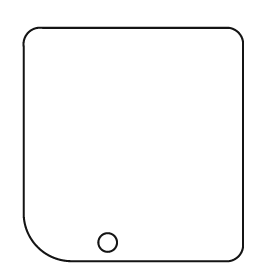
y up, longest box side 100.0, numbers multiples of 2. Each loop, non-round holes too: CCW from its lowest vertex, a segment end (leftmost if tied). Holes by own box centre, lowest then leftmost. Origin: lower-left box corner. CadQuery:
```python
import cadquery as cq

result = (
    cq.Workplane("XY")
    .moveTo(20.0, 0.0)
    .lineTo(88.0, 0.0)
    .threePointArc((92.0, 2.0), (94.0, 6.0))
    .lineTo(94.0, 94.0)
    .threePointArc((92.0, 98.0), (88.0, 100.0))
    .lineTo(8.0, 100.0)
    .threePointArc((2.0, 98.0), (0.0, 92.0))
    .lineTo(0.0, 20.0)
    .threePointArc((6.0, 6.0), (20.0, 0.0))
    .close()
    .moveTo(36.0, 8.0)
    .circle(4.0)
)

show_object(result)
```